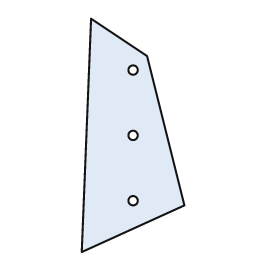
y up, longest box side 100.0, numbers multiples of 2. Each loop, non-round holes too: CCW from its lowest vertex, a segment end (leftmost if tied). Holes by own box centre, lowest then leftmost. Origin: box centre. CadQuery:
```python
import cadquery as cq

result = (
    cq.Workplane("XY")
    .moveTo(-22.0, -50.0)
    .lineTo(22.0, -30.0)
    .lineTo(6.0, 34.0)
    .lineTo(-18.0, 50.0)
    .close()
    .moveTo(0.0, -28.0)
    .circle(2.0)
    .moveTo(0.0, 0.0)
    .circle(2.0)
    .moveTo(0.0, 28.0)
    .circle(2.0)
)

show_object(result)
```